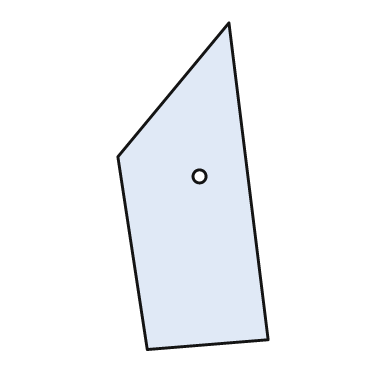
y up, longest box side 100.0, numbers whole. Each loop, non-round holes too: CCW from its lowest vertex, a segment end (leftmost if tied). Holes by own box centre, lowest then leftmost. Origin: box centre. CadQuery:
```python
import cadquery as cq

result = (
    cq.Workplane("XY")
    .moveTo(-14.0, -50.0)
    .lineTo(23.0, -47.0)
    .lineTo(11.0, 50.0)
    .lineTo(-23.0, 9.0)
    .close()
    .moveTo(2.0, 3.0)
    .circle(2.0)
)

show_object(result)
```